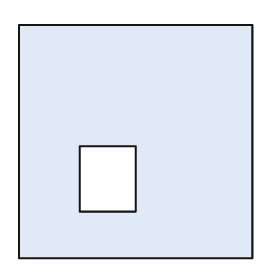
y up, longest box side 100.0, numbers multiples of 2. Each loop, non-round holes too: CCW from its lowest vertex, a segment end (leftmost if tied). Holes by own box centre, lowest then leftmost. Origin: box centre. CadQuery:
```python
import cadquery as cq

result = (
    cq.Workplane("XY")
    .moveTo(-50.0, -50.0)
    .lineTo(50.0, -50.0)
    .lineTo(50.0, 50.0)
    .lineTo(-50.0, 50.0)
    .close()
    .moveTo(-24.0, -30.0)
    .lineTo(0.0, -30.0)
    .lineTo(0.0, -2.0)
    .lineTo(-24.0, -2.0)
    .close()
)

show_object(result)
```